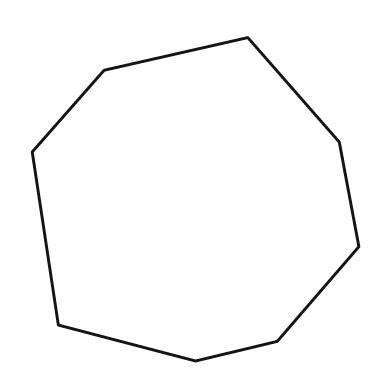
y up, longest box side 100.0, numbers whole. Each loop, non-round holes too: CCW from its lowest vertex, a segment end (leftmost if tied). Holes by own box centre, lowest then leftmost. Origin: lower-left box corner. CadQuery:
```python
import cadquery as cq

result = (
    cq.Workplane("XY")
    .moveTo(50.0, 0.0)
    .lineTo(75.0, 6.0)
    .lineTo(100.0, 35.0)
    .lineTo(94.0, 67.0)
    .lineTo(66.0, 99.0)
    .lineTo(22.0, 89.0)
    .lineTo(0.0, 64.0)
    .lineTo(8.0, 11.0)
    .close()
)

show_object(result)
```